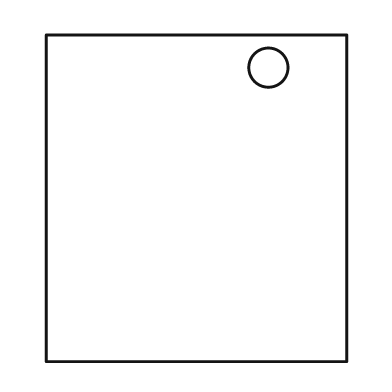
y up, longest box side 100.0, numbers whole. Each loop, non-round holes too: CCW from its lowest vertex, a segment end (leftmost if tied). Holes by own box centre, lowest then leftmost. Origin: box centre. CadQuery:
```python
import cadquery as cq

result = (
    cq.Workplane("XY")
    .moveTo(-46.0, -50.0)
    .lineTo(46.0, -50.0)
    .lineTo(46.0, 50.0)
    .lineTo(-46.0, 50.0)
    .close()
    .moveTo(22.0, 40.0)
    .circle(6.0)
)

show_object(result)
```